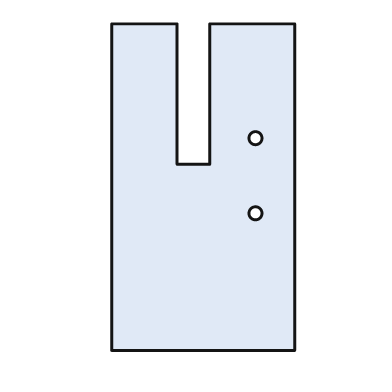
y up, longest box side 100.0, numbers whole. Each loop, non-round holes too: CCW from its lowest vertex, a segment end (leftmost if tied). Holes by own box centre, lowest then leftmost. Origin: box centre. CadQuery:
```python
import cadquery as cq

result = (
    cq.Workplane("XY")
    .moveTo(-28.0, -50.0)
    .lineTo(28.0, -50.0)
    .lineTo(28.0, 50.0)
    .lineTo(2.0, 50.0)
    .lineTo(2.0, 7.0)
    .lineTo(-8.0, 7.0)
    .lineTo(-8.0, 50.0)
    .lineTo(-28.0, 50.0)
    .close()
    .moveTo(16.0, -8.0)
    .circle(2.0)
    .moveTo(16.0, 15.0)
    .circle(2.0)
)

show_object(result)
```